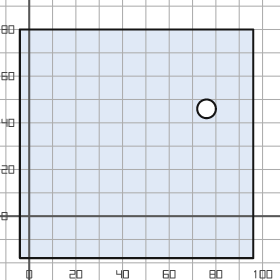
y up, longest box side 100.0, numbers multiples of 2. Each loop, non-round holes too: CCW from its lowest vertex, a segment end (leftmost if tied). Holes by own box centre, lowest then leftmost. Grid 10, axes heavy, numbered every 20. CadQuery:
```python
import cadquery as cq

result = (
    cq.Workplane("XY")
    .moveTo(-4.0, -18.0)
    .lineTo(96.0, -18.0)
    .lineTo(96.0, 80.0)
    .lineTo(-4.0, 80.0)
    .close()
    .moveTo(76.0, 46.0)
    .circle(4.0)
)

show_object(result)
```